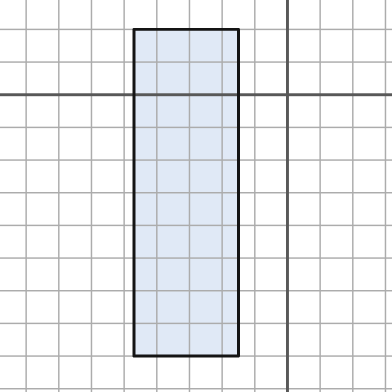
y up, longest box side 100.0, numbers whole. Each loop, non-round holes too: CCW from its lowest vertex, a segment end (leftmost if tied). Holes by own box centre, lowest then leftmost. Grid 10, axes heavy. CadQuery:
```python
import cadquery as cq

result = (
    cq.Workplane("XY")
    .moveTo(-47.0, -80.0)
    .lineTo(-15.0, -80.0)
    .lineTo(-15.0, 20.0)
    .lineTo(-47.0, 20.0)
    .close()
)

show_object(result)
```